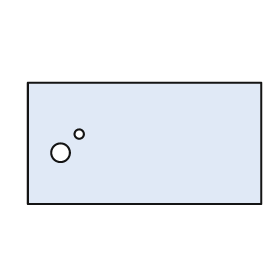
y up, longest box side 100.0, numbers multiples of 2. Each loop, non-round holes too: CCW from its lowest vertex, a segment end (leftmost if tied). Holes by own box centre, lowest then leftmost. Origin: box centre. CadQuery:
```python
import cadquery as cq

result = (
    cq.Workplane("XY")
    .moveTo(-50.0, -26.0)
    .lineTo(50.0, -26.0)
    .lineTo(50.0, 26.0)
    .lineTo(-50.0, 26.0)
    .close()
    .moveTo(-36.0, -4.0)
    .circle(4.0)
    .moveTo(-28.0, 4.0)
    .circle(2.0)
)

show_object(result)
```